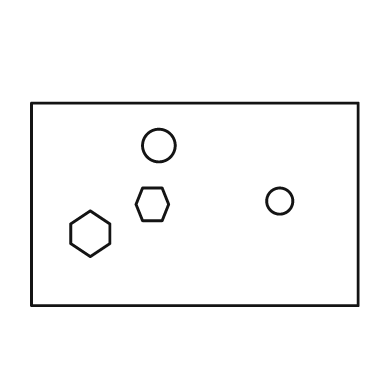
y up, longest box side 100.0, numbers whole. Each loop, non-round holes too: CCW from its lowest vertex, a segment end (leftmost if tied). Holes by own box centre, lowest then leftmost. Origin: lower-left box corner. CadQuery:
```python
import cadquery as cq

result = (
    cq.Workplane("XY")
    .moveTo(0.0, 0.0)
    .lineTo(100.0, 0.0)
    .lineTo(100.0, 62.0)
    .lineTo(0.0, 62.0)
    .close()
    .moveTo(18.0, 15.0)
    .lineTo(24.0, 19.0)
    .lineTo(24.0, 25.0)
    .lineTo(18.0, 29.0)
    .lineTo(12.0, 25.0)
    .lineTo(12.0, 19.0)
    .close()
    .moveTo(34.0, 26.0)
    .lineTo(40.0, 26.0)
    .lineTo(42.0, 31.0)
    .lineTo(40.0, 36.0)
    .lineTo(34.0, 36.0)
    .lineTo(32.0, 31.0)
    .close()
    .moveTo(76.0, 32.0)
    .circle(4.0)
    .moveTo(39.0, 49.0)
    .circle(5.0)
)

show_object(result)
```